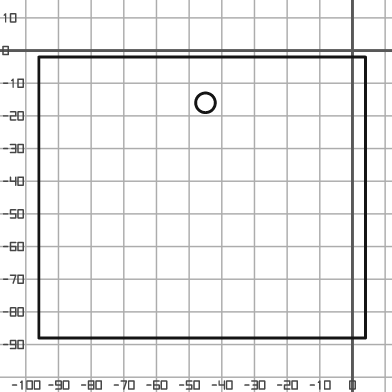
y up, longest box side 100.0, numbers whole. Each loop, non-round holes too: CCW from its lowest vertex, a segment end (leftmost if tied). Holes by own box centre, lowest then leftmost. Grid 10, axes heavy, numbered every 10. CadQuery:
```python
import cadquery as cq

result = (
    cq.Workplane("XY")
    .moveTo(-96.0, -88.0)
    .lineTo(4.0, -88.0)
    .lineTo(4.0, -2.0)
    .lineTo(-96.0, -2.0)
    .close()
    .moveTo(-45.0, -16.0)
    .circle(3.0)
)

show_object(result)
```